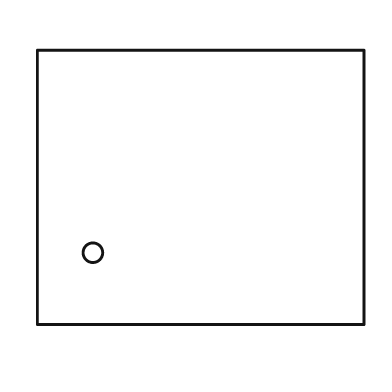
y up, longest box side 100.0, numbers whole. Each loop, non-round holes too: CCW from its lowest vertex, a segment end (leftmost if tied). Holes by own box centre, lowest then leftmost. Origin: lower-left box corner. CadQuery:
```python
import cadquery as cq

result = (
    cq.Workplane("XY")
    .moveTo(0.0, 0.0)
    .lineTo(100.0, 0.0)
    .lineTo(100.0, 84.0)
    .lineTo(0.0, 84.0)
    .close()
    .moveTo(17.0, 22.0)
    .circle(3.0)
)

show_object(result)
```